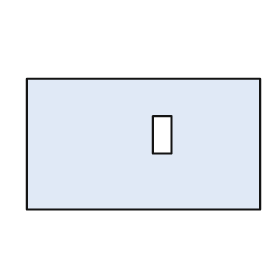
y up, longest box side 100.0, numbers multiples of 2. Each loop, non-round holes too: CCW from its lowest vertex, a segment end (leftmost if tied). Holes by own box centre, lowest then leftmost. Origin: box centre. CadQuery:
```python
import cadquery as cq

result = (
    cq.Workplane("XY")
    .moveTo(-50.0, -28.0)
    .lineTo(50.0, -28.0)
    .lineTo(50.0, 28.0)
    .lineTo(-50.0, 28.0)
    .close()
    .moveTo(4.0, -4.0)
    .lineTo(12.0, -4.0)
    .lineTo(12.0, 12.0)
    .lineTo(4.0, 12.0)
    .close()
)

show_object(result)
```